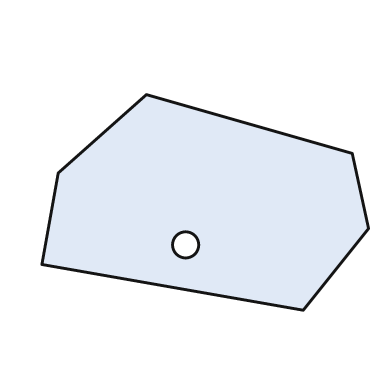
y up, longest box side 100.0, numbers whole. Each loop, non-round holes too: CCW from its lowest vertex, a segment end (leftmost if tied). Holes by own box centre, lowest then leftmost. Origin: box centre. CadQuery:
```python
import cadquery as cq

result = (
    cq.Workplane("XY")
    .moveTo(30.0, -33.0)
    .lineTo(50.0, -8.0)
    .lineTo(45.0, 15.0)
    .lineTo(-18.0, 33.0)
    .lineTo(-45.0, 9.0)
    .lineTo(-50.0, -19.0)
    .close()
    .moveTo(-6.0, -13.0)
    .circle(4.0)
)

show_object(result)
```